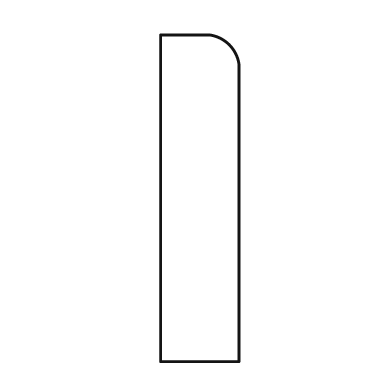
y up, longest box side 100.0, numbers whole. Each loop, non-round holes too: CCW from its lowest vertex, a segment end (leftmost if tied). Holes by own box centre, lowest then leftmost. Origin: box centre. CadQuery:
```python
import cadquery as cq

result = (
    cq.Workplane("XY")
    .moveTo(-12.0, -50.0)
    .lineTo(12.0, -50.0)
    .lineTo(12.0, 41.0)
    .threePointArc((9.0, 47.0), (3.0, 50.0))
    .lineTo(-12.0, 50.0)
    .close()
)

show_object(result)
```